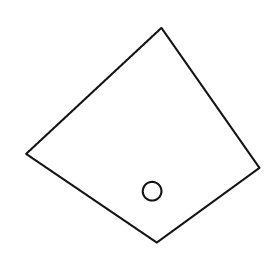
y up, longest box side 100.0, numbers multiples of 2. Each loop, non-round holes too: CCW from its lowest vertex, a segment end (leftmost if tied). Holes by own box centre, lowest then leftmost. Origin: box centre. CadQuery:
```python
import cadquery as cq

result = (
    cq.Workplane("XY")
    .moveTo(6.0, -46.0)
    .lineTo(50.0, -14.0)
    .lineTo(8.0, 46.0)
    .lineTo(-50.0, -8.0)
    .close()
    .moveTo(4.0, -24.0)
    .circle(4.0)
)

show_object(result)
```